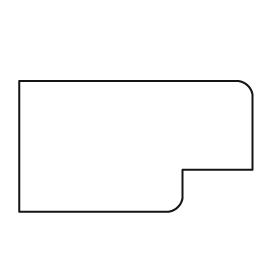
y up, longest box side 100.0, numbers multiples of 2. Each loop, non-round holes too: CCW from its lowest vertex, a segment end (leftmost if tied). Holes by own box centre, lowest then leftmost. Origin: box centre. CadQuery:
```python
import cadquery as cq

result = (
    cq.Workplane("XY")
    .moveTo(-50.0, -28.0)
    .lineTo(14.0, -28.0)
    .threePointArc((18.0, -26.0), (20.0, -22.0))
    .lineTo(20.0, -10.0)
    .lineTo(50.0, -10.0)
    .lineTo(50.0, 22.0)
    .threePointArc((48.0, 26.0), (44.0, 28.0))
    .lineTo(-50.0, 28.0)
    .close()
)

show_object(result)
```